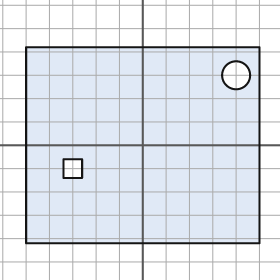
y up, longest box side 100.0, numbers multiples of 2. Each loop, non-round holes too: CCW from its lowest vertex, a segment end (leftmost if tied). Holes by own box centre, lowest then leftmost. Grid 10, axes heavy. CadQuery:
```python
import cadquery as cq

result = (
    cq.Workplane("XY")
    .moveTo(-50.0, -42.0)
    .lineTo(50.0, -42.0)
    .lineTo(50.0, 42.0)
    .lineTo(-50.0, 42.0)
    .close()
    .moveTo(-34.0, -14.0)
    .lineTo(-26.0, -14.0)
    .lineTo(-26.0, -6.0)
    .lineTo(-34.0, -6.0)
    .close()
    .moveTo(40.0, 30.0)
    .circle(6.0)
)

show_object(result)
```